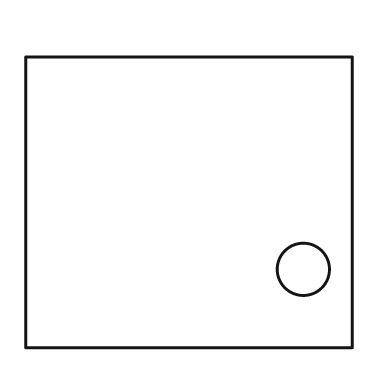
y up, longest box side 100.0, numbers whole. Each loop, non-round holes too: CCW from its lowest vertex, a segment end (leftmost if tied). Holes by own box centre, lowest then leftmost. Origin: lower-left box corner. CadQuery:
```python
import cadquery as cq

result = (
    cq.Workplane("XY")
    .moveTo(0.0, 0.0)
    .lineTo(100.0, 0.0)
    .lineTo(100.0, 89.0)
    .lineTo(0.0, 89.0)
    .close()
    .moveTo(85.0, 24.0)
    .circle(8.0)
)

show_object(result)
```